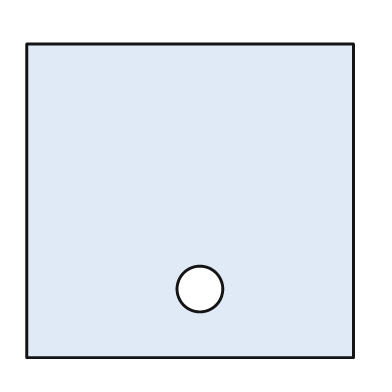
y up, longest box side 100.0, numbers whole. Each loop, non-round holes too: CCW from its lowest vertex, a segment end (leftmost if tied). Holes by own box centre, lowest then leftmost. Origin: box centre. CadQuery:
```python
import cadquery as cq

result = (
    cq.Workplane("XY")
    .moveTo(-50.0, -48.0)
    .lineTo(50.0, -48.0)
    .lineTo(50.0, 48.0)
    .lineTo(-50.0, 48.0)
    .close()
    .moveTo(3.0, -27.0)
    .circle(7.0)
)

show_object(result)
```